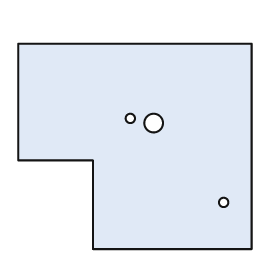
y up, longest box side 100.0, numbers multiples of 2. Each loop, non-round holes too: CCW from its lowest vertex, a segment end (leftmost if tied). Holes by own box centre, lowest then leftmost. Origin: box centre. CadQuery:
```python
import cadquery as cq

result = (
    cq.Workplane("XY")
    .moveTo(-18.0, -44.0)
    .lineTo(50.0, -44.0)
    .lineTo(50.0, 44.0)
    .lineTo(-50.0, 44.0)
    .lineTo(-50.0, -6.0)
    .lineTo(-18.0, -6.0)
    .close()
    .moveTo(38.0, -24.0)
    .circle(2.0)
    .moveTo(8.0, 10.0)
    .circle(4.0)
    .moveTo(-2.0, 12.0)
    .circle(2.0)
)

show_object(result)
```